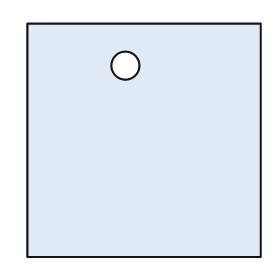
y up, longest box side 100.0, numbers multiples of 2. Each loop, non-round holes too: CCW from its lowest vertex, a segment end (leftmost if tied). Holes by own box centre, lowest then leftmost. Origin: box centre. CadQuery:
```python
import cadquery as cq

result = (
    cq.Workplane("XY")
    .moveTo(-50.0, -50.0)
    .lineTo(50.0, -50.0)
    .lineTo(50.0, 50.0)
    .lineTo(-50.0, 50.0)
    .close()
    .moveTo(-8.0, 32.0)
    .circle(6.0)
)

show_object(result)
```